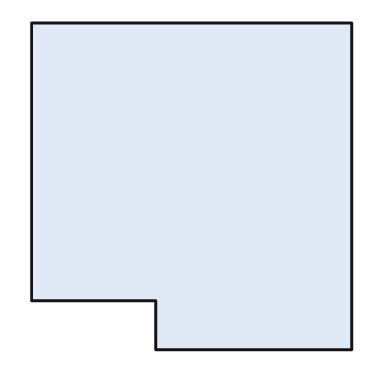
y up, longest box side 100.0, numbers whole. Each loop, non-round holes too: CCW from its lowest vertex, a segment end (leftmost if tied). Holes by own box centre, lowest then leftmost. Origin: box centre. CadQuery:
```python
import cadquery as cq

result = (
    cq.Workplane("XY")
    .moveTo(-11.0, -50.0)
    .lineTo(49.0, -50.0)
    .lineTo(49.0, 50.0)
    .lineTo(-49.0, 50.0)
    .lineTo(-49.0, -35.0)
    .lineTo(-11.0, -35.0)
    .close()
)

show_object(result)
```